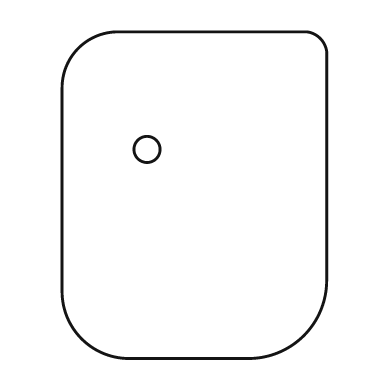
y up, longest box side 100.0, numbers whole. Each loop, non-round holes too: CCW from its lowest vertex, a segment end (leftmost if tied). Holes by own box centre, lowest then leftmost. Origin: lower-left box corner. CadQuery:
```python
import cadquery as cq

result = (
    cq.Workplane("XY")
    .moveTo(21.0, 0.0)
    .lineTo(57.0, 0.0)
    .threePointArc((74.0, 7.0), (81.0, 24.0))
    .lineTo(81.0, 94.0)
    .threePointArc((79.0, 98.0), (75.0, 100.0))
    .lineTo(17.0, 100.0)
    .threePointArc((5.0, 95.0), (0.0, 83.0))
    .lineTo(0.0, 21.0)
    .threePointArc((6.0, 6.0), (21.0, 0.0))
    .close()
    .moveTo(26.0, 64.0)
    .circle(4.0)
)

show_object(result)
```